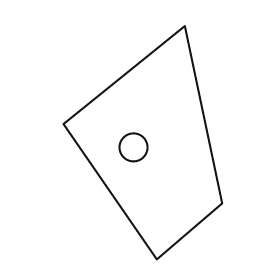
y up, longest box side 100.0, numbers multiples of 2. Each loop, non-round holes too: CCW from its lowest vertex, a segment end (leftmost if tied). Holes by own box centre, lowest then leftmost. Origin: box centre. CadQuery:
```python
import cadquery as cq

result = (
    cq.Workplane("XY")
    .moveTo(6.0, -50.0)
    .lineTo(34.0, -26.0)
    .lineTo(18.0, 50.0)
    .lineTo(-34.0, 8.0)
    .close()
    .moveTo(-4.0, -2.0)
    .circle(6.0)
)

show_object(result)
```